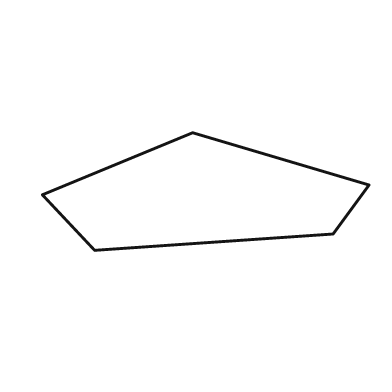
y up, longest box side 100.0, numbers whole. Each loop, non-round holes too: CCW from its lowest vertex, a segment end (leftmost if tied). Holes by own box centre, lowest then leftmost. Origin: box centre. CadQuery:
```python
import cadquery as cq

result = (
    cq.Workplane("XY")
    .moveTo(-34.0, -18.0)
    .lineTo(39.0, -13.0)
    .lineTo(50.0, 2.0)
    .lineTo(-4.0, 18.0)
    .lineTo(-50.0, -1.0)
    .close()
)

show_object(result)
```